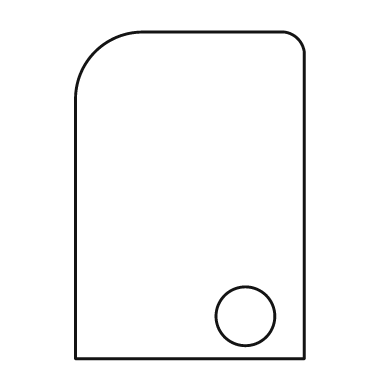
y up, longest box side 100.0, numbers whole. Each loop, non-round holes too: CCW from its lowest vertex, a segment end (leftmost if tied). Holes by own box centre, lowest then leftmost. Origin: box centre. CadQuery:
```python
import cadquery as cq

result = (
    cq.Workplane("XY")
    .moveTo(-35.0, -50.0)
    .lineTo(35.0, -50.0)
    .lineTo(35.0, 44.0)
    .threePointArc((33.0, 48.0), (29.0, 50.0))
    .lineTo(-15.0, 50.0)
    .threePointArc((-29.0, 44.0), (-35.0, 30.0))
    .close()
    .moveTo(17.0, -37.0)
    .circle(9.0)
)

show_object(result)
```